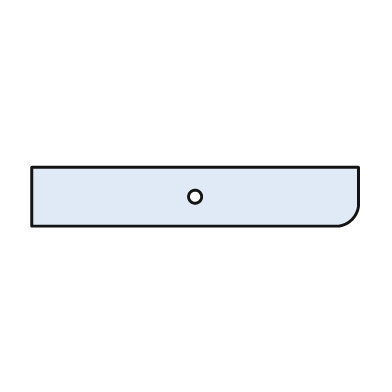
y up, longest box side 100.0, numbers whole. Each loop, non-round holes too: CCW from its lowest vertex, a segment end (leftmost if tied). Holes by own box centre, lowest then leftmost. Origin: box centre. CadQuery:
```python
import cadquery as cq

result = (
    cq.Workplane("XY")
    .moveTo(-50.0, -9.0)
    .lineTo(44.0, -9.0)
    .threePointArc((48.0, -7.0), (50.0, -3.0))
    .lineTo(50.0, 9.0)
    .lineTo(-50.0, 9.0)
    .close()
    .moveTo(0.0, 0.0)
    .circle(2.0)
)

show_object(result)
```